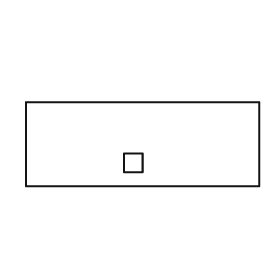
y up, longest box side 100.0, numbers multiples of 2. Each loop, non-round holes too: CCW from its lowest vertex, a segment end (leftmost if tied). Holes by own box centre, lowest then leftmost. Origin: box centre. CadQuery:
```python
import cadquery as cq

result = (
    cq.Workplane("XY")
    .moveTo(-50.0, -18.0)
    .lineTo(50.0, -18.0)
    .lineTo(50.0, 18.0)
    .lineTo(-50.0, 18.0)
    .close()
    .moveTo(-8.0, -12.0)
    .lineTo(0.0, -12.0)
    .lineTo(0.0, -4.0)
    .lineTo(-8.0, -4.0)
    .close()
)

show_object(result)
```